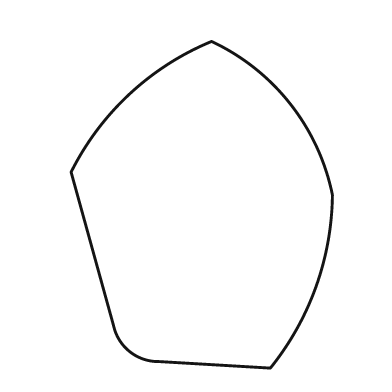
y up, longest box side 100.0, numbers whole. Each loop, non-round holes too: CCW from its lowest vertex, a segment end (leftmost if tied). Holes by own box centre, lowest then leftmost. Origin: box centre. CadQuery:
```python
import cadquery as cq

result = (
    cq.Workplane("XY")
    .moveTo(21.0, -50.0)
    .threePointArc((35.0, -25.0), (40.0, 3.0))
    .threePointArc((27.0, 31.0), (3.0, 50.0))
    .threePointArc((-22.0, 34.0), (-40.0, 10.0))
    .lineTo(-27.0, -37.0)
    .threePointArc((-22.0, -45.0), (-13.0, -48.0))
    .close()
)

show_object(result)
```